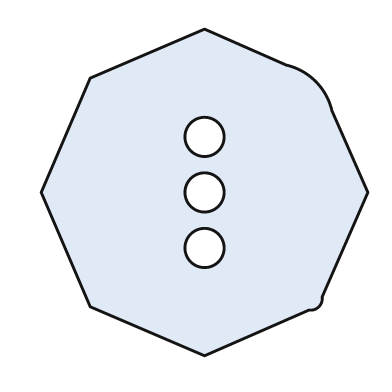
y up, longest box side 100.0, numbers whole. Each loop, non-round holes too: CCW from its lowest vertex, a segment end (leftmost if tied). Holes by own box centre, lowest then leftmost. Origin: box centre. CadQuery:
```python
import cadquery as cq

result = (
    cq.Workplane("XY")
    .moveTo(0.0, -50.0)
    .lineTo(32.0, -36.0)
    .threePointArc((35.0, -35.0), (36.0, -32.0))
    .lineTo(50.0, 0.0)
    .lineTo(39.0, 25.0)
    .threePointArc((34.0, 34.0), (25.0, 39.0))
    .lineTo(0.0, 50.0)
    .lineTo(-35.0, 35.0)
    .lineTo(-50.0, 0.0)
    .lineTo(-35.0, -35.0)
    .close()
    .moveTo(0.0, -17.0)
    .circle(6.0)
    .moveTo(0.0, 0.0)
    .circle(6.0)
    .moveTo(0.0, 17.0)
    .circle(6.0)
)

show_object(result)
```